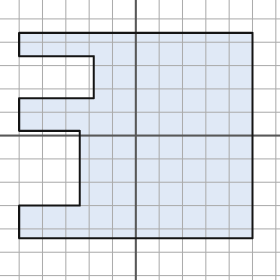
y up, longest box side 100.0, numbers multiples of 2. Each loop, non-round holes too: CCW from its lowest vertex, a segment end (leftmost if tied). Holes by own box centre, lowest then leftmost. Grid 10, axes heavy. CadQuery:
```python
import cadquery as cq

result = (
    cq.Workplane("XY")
    .moveTo(-50.0, -44.0)
    .lineTo(50.0, -44.0)
    .lineTo(50.0, 44.0)
    .lineTo(-50.0, 44.0)
    .lineTo(-50.0, 34.0)
    .lineTo(-18.0, 34.0)
    .lineTo(-18.0, 16.0)
    .lineTo(-50.0, 16.0)
    .lineTo(-50.0, 2.0)
    .lineTo(-24.0, 2.0)
    .lineTo(-24.0, -30.0)
    .lineTo(-50.0, -30.0)
    .close()
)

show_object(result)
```